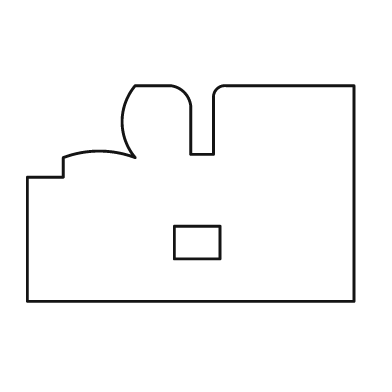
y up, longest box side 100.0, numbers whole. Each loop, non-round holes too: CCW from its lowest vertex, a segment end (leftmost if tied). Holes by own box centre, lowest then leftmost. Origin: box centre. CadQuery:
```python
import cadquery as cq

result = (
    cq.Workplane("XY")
    .moveTo(-50.0, -33.0)
    .lineTo(50.0, -33.0)
    .lineTo(50.0, 33.0)
    .lineTo(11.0, 33.0)
    .threePointArc((8.0, 32.0), (7.0, 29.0))
    .lineTo(7.0, 12.0)
    .lineTo(0.0, 12.0)
    .lineTo(0.0, 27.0)
    .threePointArc((-2.0, 31.0), (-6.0, 33.0))
    .lineTo(-17.0, 33.0)
    .threePointArc((-21.0, 22.0), (-17.0, 11.0))
    .threePointArc((-28.0, 13.0), (-39.0, 11.0))
    .lineTo(-39.0, 5.0)
    .lineTo(-50.0, 5.0)
    .close()
    .moveTo(-5.0, -20.0)
    .lineTo(9.0, -20.0)
    .lineTo(9.0, -10.0)
    .lineTo(-5.0, -10.0)
    .close()
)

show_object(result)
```